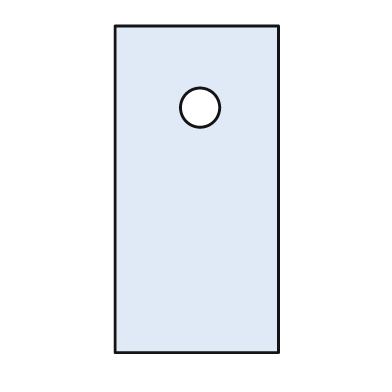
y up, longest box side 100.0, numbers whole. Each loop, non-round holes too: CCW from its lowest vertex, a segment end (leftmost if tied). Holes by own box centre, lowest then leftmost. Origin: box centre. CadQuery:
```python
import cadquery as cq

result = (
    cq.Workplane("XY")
    .moveTo(-25.0, -50.0)
    .lineTo(25.0, -50.0)
    .lineTo(25.0, 50.0)
    .lineTo(-25.0, 50.0)
    .close()
    .moveTo(1.0, 25.0)
    .circle(6.0)
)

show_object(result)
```